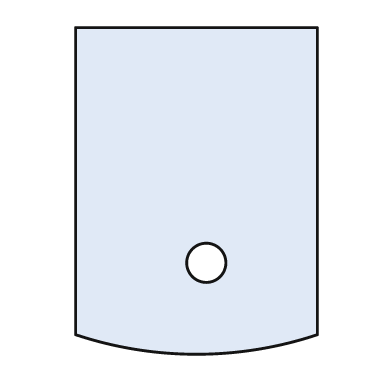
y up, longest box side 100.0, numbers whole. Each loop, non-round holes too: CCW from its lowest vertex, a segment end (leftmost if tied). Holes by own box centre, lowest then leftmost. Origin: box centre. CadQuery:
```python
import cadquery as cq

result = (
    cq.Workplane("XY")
    .moveTo(-37.0, -44.0)
    .threePointArc((0.0, -50.0), (37.0, -44.0))
    .lineTo(37.0, 50.0)
    .lineTo(-37.0, 50.0)
    .close()
    .moveTo(3.0, -22.0)
    .circle(6.0)
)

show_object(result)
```